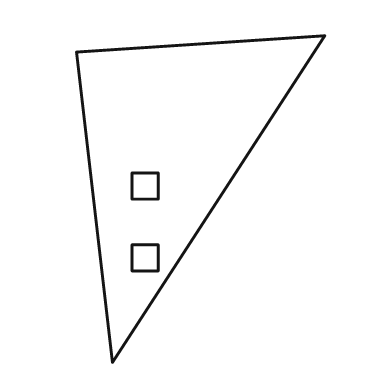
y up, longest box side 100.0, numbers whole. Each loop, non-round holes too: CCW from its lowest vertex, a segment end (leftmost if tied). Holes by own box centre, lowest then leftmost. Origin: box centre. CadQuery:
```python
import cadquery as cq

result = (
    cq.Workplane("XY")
    .moveTo(-27.0, -50.0)
    .lineTo(38.0, 50.0)
    .lineTo(-38.0, 45.0)
    .close()
    .moveTo(-21.0, -22.0)
    .lineTo(-13.0, -22.0)
    .lineTo(-13.0, -14.0)
    .lineTo(-21.0, -14.0)
    .close()
    .moveTo(-21.0, 0.0)
    .lineTo(-13.0, 0.0)
    .lineTo(-13.0, 8.0)
    .lineTo(-21.0, 8.0)
    .close()
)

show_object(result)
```